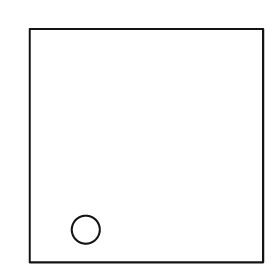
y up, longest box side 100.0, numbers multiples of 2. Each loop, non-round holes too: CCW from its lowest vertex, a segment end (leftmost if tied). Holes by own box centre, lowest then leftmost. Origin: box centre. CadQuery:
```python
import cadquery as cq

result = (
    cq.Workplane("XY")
    .moveTo(-50.0, -50.0)
    .lineTo(50.0, -50.0)
    .lineTo(50.0, 50.0)
    .lineTo(-50.0, 50.0)
    .close()
    .moveTo(-26.0, -36.0)
    .circle(6.0)
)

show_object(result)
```